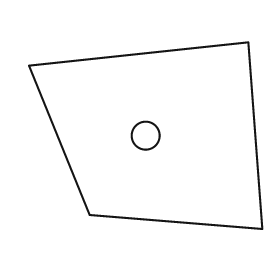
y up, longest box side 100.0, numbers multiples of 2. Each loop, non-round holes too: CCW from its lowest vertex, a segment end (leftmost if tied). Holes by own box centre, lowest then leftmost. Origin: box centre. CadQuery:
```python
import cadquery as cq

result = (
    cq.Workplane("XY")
    .moveTo(50.0, -40.0)
    .lineTo(44.0, 40.0)
    .lineTo(-50.0, 30.0)
    .lineTo(-24.0, -34.0)
    .close()
    .moveTo(0.0, 0.0)
    .circle(6.0)
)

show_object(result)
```